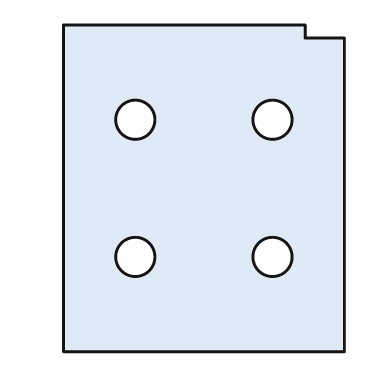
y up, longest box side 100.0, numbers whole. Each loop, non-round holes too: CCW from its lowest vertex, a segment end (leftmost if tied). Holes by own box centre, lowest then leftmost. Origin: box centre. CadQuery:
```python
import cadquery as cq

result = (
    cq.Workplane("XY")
    .moveTo(-43.0, -50.0)
    .lineTo(43.0, -50.0)
    .lineTo(43.0, 46.0)
    .lineTo(31.0, 46.0)
    .lineTo(31.0, 50.0)
    .lineTo(-43.0, 50.0)
    .close()
    .moveTo(-21.0, -21.0)
    .circle(6.0)
    .moveTo(21.0, -21.0)
    .circle(6.0)
    .moveTo(-21.0, 21.0)
    .circle(6.0)
    .moveTo(21.0, 21.0)
    .circle(6.0)
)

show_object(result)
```